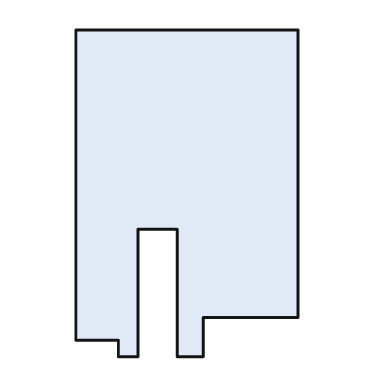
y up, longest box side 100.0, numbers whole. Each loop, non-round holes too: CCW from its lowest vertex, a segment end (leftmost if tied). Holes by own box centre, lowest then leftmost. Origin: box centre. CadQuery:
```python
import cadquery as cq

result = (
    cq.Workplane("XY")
    .moveTo(-21.0, -50.0)
    .lineTo(-15.0, -50.0)
    .lineTo(-15.0, -11.0)
    .lineTo(-3.0, -11.0)
    .lineTo(-3.0, -50.0)
    .lineTo(5.0, -50.0)
    .lineTo(5.0, -38.0)
    .lineTo(34.0, -38.0)
    .lineTo(34.0, 50.0)
    .lineTo(-34.0, 50.0)
    .lineTo(-34.0, -45.0)
    .lineTo(-21.0, -45.0)
    .close()
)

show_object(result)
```